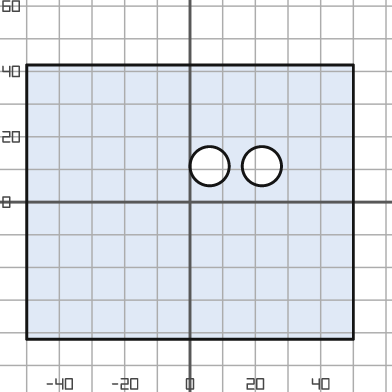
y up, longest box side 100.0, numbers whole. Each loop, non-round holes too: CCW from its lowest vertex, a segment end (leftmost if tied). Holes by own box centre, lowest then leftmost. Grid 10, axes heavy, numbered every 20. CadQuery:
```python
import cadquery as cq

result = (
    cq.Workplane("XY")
    .moveTo(-50.0, -42.0)
    .lineTo(50.0, -42.0)
    .lineTo(50.0, 42.0)
    .lineTo(-50.0, 42.0)
    .close()
    .moveTo(6.0, 11.0)
    .circle(6.0)
    .moveTo(22.0, 11.0)
    .circle(6.0)
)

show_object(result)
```